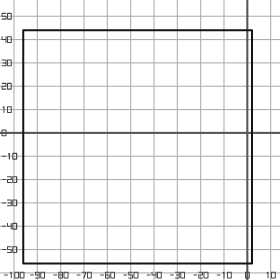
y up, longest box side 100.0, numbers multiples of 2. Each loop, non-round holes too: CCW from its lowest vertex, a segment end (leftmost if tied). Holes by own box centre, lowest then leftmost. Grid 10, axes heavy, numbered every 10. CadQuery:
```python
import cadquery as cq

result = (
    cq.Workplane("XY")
    .moveTo(-96.0, -56.0)
    .lineTo(2.0, -56.0)
    .lineTo(2.0, 44.0)
    .lineTo(-96.0, 44.0)
    .close()
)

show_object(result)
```